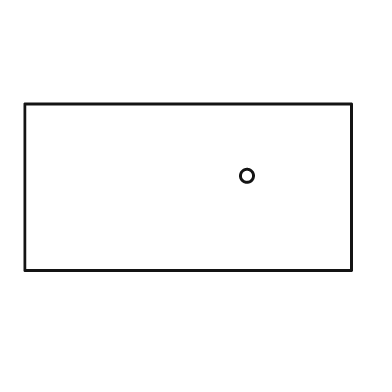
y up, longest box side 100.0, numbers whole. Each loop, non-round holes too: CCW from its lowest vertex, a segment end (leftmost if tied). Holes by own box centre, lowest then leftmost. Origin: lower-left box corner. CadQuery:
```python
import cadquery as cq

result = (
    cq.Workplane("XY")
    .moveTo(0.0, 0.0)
    .lineTo(100.0, 0.0)
    .lineTo(100.0, 51.0)
    .lineTo(0.0, 51.0)
    .close()
    .moveTo(68.0, 29.0)
    .circle(2.0)
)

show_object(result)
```